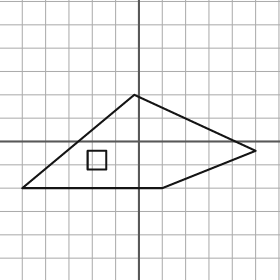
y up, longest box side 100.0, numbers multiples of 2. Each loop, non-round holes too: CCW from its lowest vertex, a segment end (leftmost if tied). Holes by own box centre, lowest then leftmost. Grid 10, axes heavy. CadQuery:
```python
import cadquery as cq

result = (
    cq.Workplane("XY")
    .moveTo(-50.0, -20.0)
    .lineTo(10.0, -20.0)
    .lineTo(50.0, -4.0)
    .lineTo(-2.0, 20.0)
    .close()
    .moveTo(-22.0, -12.0)
    .lineTo(-14.0, -12.0)
    .lineTo(-14.0, -4.0)
    .lineTo(-22.0, -4.0)
    .close()
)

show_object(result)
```